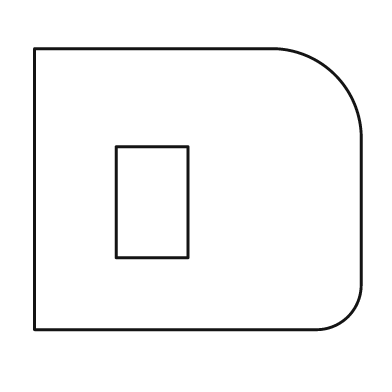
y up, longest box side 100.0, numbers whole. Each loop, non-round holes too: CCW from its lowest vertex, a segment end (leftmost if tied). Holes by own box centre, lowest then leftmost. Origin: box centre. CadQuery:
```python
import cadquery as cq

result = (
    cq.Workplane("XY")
    .moveTo(-50.0, -43.0)
    .lineTo(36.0, -43.0)
    .threePointArc((46.0, -39.0), (50.0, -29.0))
    .lineTo(50.0, 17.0)
    .threePointArc((42.0, 35.0), (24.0, 43.0))
    .lineTo(-50.0, 43.0)
    .close()
    .moveTo(-25.0, -21.0)
    .lineTo(-3.0, -21.0)
    .lineTo(-3.0, 13.0)
    .lineTo(-25.0, 13.0)
    .close()
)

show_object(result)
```